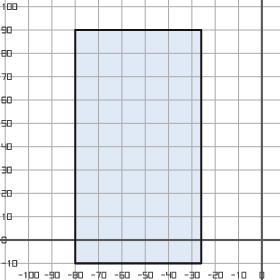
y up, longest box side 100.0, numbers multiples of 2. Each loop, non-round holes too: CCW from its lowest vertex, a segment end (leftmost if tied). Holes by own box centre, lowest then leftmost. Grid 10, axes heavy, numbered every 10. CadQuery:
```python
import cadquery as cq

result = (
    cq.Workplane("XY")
    .moveTo(-80.0, -10.0)
    .lineTo(-26.0, -10.0)
    .lineTo(-26.0, 90.0)
    .lineTo(-80.0, 90.0)
    .close()
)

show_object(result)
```